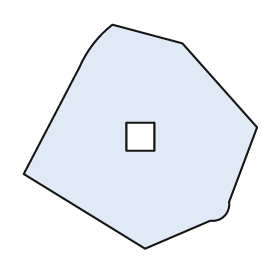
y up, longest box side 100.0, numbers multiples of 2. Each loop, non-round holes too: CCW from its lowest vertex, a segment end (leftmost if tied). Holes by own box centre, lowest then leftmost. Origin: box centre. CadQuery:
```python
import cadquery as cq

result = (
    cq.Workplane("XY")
    .moveTo(2.0, -48.0)
    .lineTo(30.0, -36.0)
    .threePointArc((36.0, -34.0), (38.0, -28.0))
    .lineTo(50.0, 4.0)
    .lineTo(18.0, 40.0)
    .lineTo(-12.0, 48.0)
    .threePointArc((-20.0, 40.0), (-26.0, 30.0))
    .lineTo(-50.0, -16.0)
    .close()
    .moveTo(-6.0, -6.0)
    .lineTo(6.0, -6.0)
    .lineTo(6.0, 6.0)
    .lineTo(-6.0, 6.0)
    .close()
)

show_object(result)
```